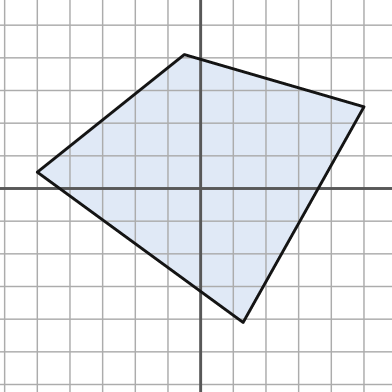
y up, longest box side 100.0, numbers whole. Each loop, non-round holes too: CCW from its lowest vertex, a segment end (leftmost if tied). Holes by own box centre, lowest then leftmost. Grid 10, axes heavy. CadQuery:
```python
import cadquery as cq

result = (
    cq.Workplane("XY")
    .moveTo(13.0, -41.0)
    .lineTo(50.0, 25.0)
    .lineTo(-5.0, 41.0)
    .lineTo(-50.0, 5.0)
    .close()
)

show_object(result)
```